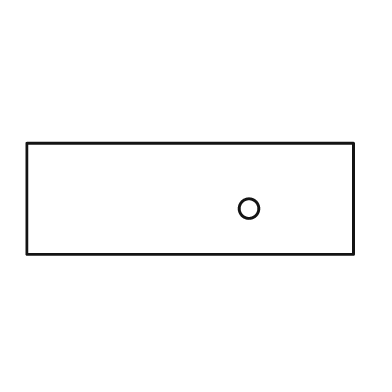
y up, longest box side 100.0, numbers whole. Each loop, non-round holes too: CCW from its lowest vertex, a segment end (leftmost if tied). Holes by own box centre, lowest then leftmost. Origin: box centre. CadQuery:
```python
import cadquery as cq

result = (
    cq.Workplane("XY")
    .moveTo(-50.0, -17.0)
    .lineTo(50.0, -17.0)
    .lineTo(50.0, 17.0)
    .lineTo(-50.0, 17.0)
    .close()
    .moveTo(18.0, -3.0)
    .circle(3.0)
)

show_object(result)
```